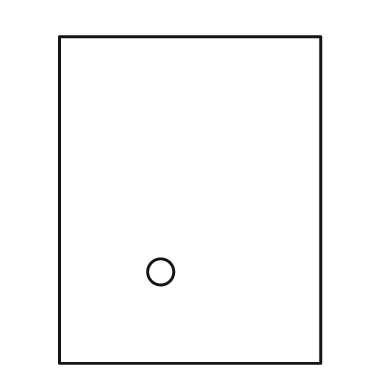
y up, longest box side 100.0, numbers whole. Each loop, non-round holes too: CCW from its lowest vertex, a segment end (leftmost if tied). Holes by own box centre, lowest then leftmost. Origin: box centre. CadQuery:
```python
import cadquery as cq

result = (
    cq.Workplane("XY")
    .moveTo(-40.0, -50.0)
    .lineTo(40.0, -50.0)
    .lineTo(40.0, 50.0)
    .lineTo(-40.0, 50.0)
    .close()
    .moveTo(-9.0, -22.0)
    .circle(4.0)
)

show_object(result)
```